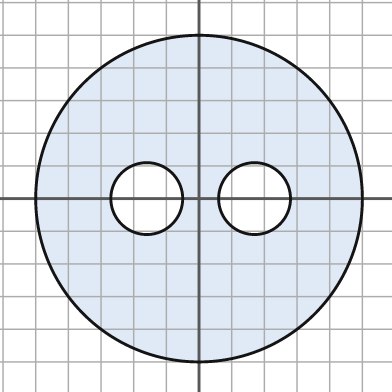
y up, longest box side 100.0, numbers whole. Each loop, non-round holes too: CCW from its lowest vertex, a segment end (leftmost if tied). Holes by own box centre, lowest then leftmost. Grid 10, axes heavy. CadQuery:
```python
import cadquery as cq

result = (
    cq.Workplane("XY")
    .moveTo(0.0, 0.0)
    .circle(50.0)
    .moveTo(-16.0, 0.0)
    .circle(11.0)
    .moveTo(17.0, 0.0)
    .circle(11.0)
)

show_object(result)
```